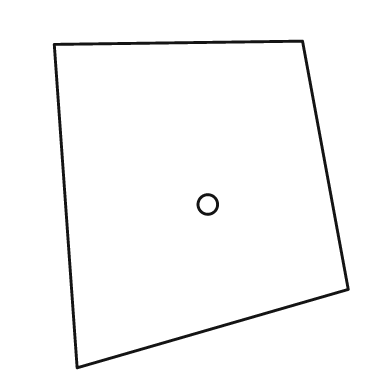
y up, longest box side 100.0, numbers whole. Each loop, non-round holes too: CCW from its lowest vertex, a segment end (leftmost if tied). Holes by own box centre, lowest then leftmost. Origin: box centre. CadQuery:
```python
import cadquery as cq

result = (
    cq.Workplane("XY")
    .moveTo(-38.0, -50.0)
    .lineTo(45.0, -26.0)
    .lineTo(31.0, 50.0)
    .lineTo(-45.0, 49.0)
    .close()
    .moveTo(2.0, 0.0)
    .circle(3.0)
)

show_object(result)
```